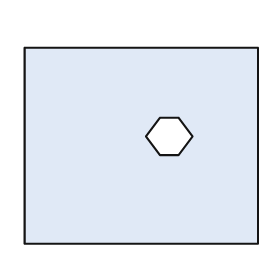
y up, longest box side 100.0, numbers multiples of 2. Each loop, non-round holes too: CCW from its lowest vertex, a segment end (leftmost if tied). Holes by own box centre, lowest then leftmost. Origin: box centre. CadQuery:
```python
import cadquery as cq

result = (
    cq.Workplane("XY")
    .moveTo(-50.0, -42.0)
    .lineTo(50.0, -42.0)
    .lineTo(50.0, 42.0)
    .lineTo(-50.0, 42.0)
    .close()
    .moveTo(8.0, -4.0)
    .lineTo(16.0, -4.0)
    .lineTo(22.0, 4.0)
    .lineTo(16.0, 12.0)
    .lineTo(8.0, 12.0)
    .lineTo(2.0, 4.0)
    .close()
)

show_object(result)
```